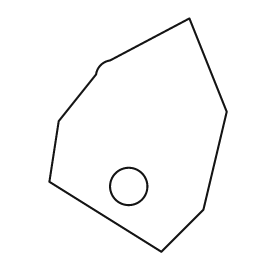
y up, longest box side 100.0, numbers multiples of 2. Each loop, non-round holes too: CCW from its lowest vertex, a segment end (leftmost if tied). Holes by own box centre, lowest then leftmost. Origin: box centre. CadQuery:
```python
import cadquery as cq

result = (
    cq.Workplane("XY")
    .moveTo(10.0, -50.0)
    .lineTo(28.0, -32.0)
    .lineTo(38.0, 10.0)
    .lineTo(22.0, 50.0)
    .lineTo(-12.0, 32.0)
    .threePointArc((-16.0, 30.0), (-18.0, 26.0))
    .lineTo(-34.0, 6.0)
    .lineTo(-38.0, -20.0)
    .close()
    .moveTo(-4.0, -22.0)
    .circle(8.0)
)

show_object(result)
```